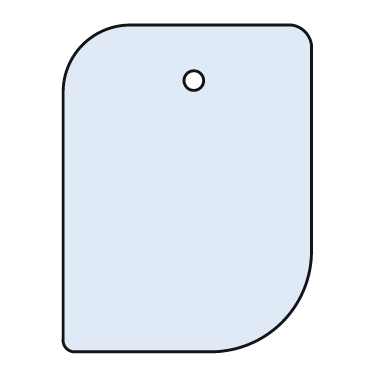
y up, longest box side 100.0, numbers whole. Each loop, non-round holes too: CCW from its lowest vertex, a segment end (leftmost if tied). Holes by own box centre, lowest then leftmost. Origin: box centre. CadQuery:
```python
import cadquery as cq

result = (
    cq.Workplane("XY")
    .moveTo(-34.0, -50.0)
    .lineTo(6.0, -50.0)
    .threePointArc((29.0, -41.0), (38.0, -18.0))
    .lineTo(38.0, 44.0)
    .threePointArc((36.0, 48.0), (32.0, 50.0))
    .lineTo(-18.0, 50.0)
    .threePointArc((-32.0, 44.0), (-38.0, 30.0))
    .lineTo(-38.0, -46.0)
    .threePointArc((-37.0, -49.0), (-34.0, -50.0))
    .close()
    .moveTo(2.0, 33.0)
    .circle(3.0)
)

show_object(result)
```